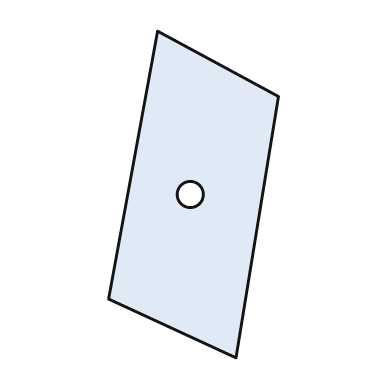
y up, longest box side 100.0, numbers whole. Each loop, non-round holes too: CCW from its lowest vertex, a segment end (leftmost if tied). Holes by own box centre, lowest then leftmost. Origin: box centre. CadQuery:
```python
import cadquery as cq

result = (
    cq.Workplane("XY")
    .moveTo(13.0, -50.0)
    .lineTo(26.0, 30.0)
    .lineTo(-11.0, 50.0)
    .lineTo(-26.0, -32.0)
    .close()
    .moveTo(-1.0, 0.0)
    .circle(4.0)
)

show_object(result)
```